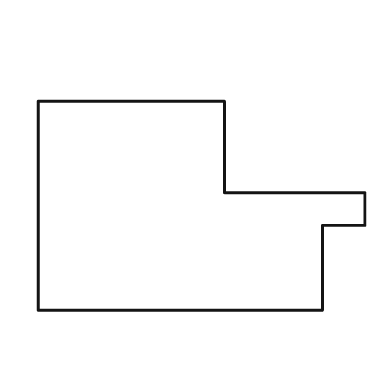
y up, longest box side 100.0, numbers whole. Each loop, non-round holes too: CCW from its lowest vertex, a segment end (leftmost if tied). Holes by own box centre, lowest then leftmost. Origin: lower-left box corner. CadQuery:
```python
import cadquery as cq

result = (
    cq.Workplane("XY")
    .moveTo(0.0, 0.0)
    .lineTo(87.0, 0.0)
    .lineTo(87.0, 26.0)
    .lineTo(100.0, 26.0)
    .lineTo(100.0, 36.0)
    .lineTo(57.0, 36.0)
    .lineTo(57.0, 64.0)
    .lineTo(0.0, 64.0)
    .close()
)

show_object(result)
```